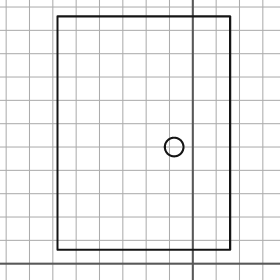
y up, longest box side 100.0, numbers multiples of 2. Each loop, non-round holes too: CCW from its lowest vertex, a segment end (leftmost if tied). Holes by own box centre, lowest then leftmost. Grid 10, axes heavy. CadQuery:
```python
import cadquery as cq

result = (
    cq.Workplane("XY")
    .moveTo(-58.0, 6.0)
    .lineTo(16.0, 6.0)
    .lineTo(16.0, 106.0)
    .lineTo(-58.0, 106.0)
    .close()
    .moveTo(-8.0, 50.0)
    .circle(4.0)
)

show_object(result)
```